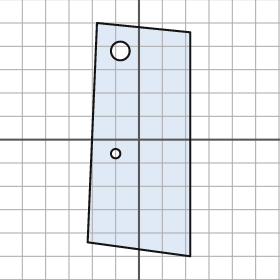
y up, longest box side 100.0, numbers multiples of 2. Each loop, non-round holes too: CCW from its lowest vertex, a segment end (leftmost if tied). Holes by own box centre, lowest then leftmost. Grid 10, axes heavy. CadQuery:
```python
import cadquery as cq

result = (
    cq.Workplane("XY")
    .moveTo(22.0, -50.0)
    .lineTo(22.0, 46.0)
    .lineTo(-18.0, 50.0)
    .lineTo(-22.0, -44.0)
    .close()
    .moveTo(-10.0, -6.0)
    .circle(2.0)
    .moveTo(-8.0, 38.0)
    .circle(4.0)
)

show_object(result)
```